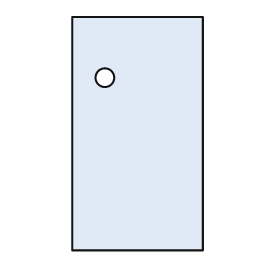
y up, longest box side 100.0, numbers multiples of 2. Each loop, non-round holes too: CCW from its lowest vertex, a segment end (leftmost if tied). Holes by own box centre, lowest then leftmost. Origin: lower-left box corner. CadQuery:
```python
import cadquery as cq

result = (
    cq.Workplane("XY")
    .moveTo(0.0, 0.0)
    .lineTo(56.0, 0.0)
    .lineTo(56.0, 100.0)
    .lineTo(0.0, 100.0)
    .close()
    .moveTo(14.0, 74.0)
    .circle(4.0)
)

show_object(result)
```